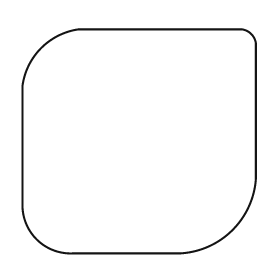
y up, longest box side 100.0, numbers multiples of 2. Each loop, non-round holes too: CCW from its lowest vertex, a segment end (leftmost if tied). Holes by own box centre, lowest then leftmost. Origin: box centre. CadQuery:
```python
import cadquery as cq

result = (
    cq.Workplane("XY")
    .moveTo(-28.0, -48.0)
    .lineTo(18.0, -48.0)
    .threePointArc((40.0, -38.0), (50.0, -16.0))
    .lineTo(50.0, 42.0)
    .threePointArc((48.0, 46.0), (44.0, 48.0))
    .lineTo(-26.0, 48.0)
    .threePointArc((-42.0, 40.0), (-50.0, 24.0))
    .lineTo(-50.0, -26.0)
    .threePointArc((-44.0, -42.0), (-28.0, -48.0))
    .close()
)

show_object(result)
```